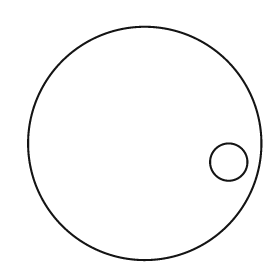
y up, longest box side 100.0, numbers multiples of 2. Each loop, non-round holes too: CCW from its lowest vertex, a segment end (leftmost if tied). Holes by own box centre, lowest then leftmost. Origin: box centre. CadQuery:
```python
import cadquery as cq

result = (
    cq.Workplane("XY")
    .moveTo(0.0, 0.0)
    .circle(50.0)
    .moveTo(36.0, -8.0)
    .circle(8.0)
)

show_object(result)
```